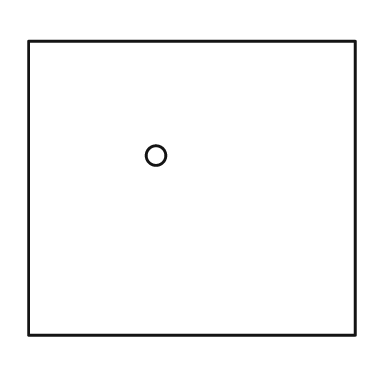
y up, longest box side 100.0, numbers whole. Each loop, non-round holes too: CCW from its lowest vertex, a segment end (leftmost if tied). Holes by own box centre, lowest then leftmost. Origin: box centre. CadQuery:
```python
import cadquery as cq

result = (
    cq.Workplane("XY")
    .moveTo(-50.0, -45.0)
    .lineTo(50.0, -45.0)
    .lineTo(50.0, 45.0)
    .lineTo(-50.0, 45.0)
    .close()
    .moveTo(-11.0, 10.0)
    .circle(3.0)
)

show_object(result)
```